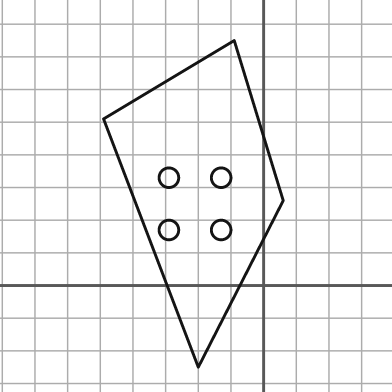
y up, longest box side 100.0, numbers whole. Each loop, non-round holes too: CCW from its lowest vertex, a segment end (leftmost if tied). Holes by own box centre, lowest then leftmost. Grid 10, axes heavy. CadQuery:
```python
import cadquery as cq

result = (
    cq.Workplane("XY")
    .moveTo(-20.0, -25.0)
    .lineTo(6.0, 26.0)
    .lineTo(-9.0, 75.0)
    .lineTo(-49.0, 51.0)
    .close()
    .moveTo(-29.0, 17.0)
    .circle(3.0)
    .moveTo(-13.0, 17.0)
    .circle(3.0)
    .moveTo(-29.0, 33.0)
    .circle(3.0)
    .moveTo(-13.0, 33.0)
    .circle(3.0)
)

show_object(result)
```